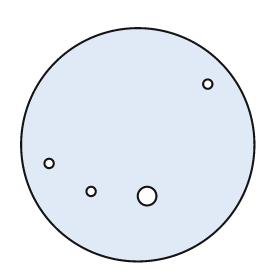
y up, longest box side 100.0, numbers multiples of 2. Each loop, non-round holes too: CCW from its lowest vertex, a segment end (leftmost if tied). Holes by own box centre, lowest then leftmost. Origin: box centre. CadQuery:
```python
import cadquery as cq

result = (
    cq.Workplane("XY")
    .moveTo(0.0, 0.0)
    .circle(50.0)
    .moveTo(4.0, -22.0)
    .circle(4.0)
    .moveTo(-20.0, -20.0)
    .circle(2.0)
    .moveTo(-38.0, -8.0)
    .circle(2.0)
    .moveTo(30.0, 26.0)
    .circle(2.0)
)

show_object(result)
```